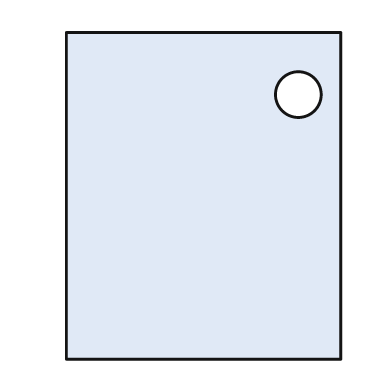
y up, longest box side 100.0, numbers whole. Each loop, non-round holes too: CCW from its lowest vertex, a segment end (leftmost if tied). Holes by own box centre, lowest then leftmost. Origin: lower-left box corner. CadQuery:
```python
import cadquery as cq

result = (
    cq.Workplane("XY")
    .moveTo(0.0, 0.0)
    .lineTo(84.0, 0.0)
    .lineTo(84.0, 100.0)
    .lineTo(0.0, 100.0)
    .close()
    .moveTo(71.0, 81.0)
    .circle(7.0)
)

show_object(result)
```